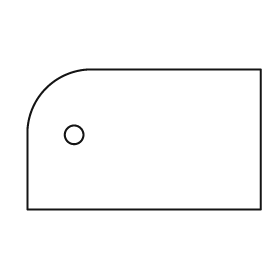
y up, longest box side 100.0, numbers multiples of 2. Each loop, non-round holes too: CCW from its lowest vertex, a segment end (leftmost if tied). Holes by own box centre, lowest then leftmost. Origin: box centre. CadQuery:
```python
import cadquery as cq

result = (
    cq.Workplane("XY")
    .moveTo(-50.0, -30.0)
    .lineTo(50.0, -30.0)
    .lineTo(50.0, 30.0)
    .lineTo(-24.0, 30.0)
    .threePointArc((-42.0, 22.0), (-50.0, 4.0))
    .close()
    .moveTo(-30.0, 2.0)
    .circle(4.0)
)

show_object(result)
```